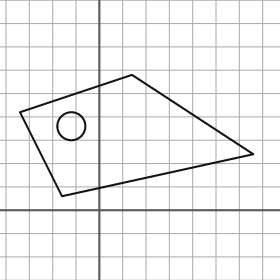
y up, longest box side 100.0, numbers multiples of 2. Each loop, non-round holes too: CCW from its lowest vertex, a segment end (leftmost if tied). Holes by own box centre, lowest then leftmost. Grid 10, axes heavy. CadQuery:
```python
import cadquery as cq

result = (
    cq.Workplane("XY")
    .moveTo(-16.0, 6.0)
    .lineTo(66.0, 24.0)
    .lineTo(14.0, 58.0)
    .lineTo(-34.0, 42.0)
    .close()
    .moveTo(-12.0, 36.0)
    .circle(6.0)
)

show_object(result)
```